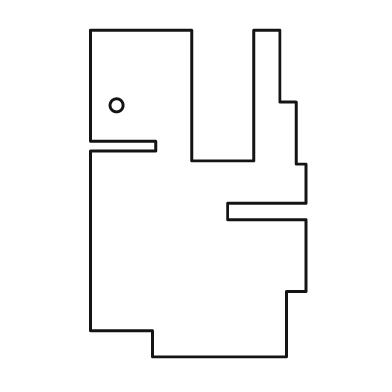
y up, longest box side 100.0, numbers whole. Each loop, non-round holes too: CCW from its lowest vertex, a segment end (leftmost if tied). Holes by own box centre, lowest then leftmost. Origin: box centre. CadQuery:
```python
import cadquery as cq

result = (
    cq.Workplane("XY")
    .moveTo(-14.0, -50.0)
    .lineTo(27.0, -50.0)
    .lineTo(27.0, -30.0)
    .lineTo(33.0, -30.0)
    .lineTo(33.0, -8.0)
    .lineTo(9.0, -8.0)
    .lineTo(9.0, -3.0)
    .lineTo(33.0, -3.0)
    .lineTo(33.0, 9.0)
    .lineTo(30.0, 9.0)
    .lineTo(30.0, 28.0)
    .lineTo(25.0, 28.0)
    .lineTo(25.0, 50.0)
    .lineTo(17.0, 50.0)
    .lineTo(17.0, 10.0)
    .lineTo(-2.0, 10.0)
    .lineTo(-2.0, 50.0)
    .lineTo(-33.0, 50.0)
    .lineTo(-33.0, 16.0)
    .lineTo(-13.0, 16.0)
    .lineTo(-13.0, 13.0)
    .lineTo(-33.0, 13.0)
    .lineTo(-33.0, -42.0)
    .lineTo(-14.0, -42.0)
    .close()
    .moveTo(-25.0, 27.0)
    .circle(2.0)
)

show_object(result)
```